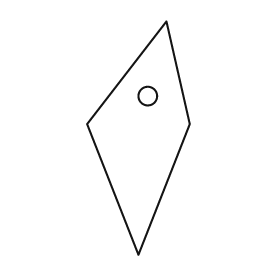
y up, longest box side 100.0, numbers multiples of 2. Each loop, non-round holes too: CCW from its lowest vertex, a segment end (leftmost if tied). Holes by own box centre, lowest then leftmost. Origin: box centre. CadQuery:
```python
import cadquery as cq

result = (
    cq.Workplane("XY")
    .moveTo(0.0, -50.0)
    .lineTo(22.0, 6.0)
    .lineTo(12.0, 50.0)
    .lineTo(-22.0, 6.0)
    .close()
    .moveTo(4.0, 18.0)
    .circle(4.0)
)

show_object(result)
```